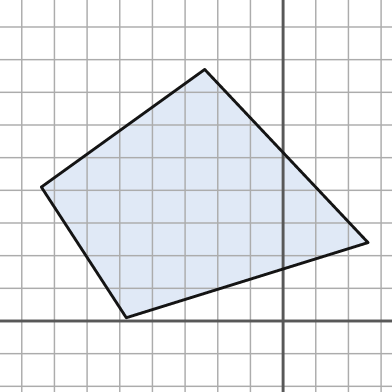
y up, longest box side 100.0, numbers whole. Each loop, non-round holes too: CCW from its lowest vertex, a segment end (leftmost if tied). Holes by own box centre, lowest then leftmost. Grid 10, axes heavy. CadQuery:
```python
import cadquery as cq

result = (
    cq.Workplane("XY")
    .moveTo(-48.0, 1.0)
    .lineTo(26.0, 24.0)
    .lineTo(-24.0, 77.0)
    .lineTo(-74.0, 41.0)
    .close()
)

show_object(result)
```